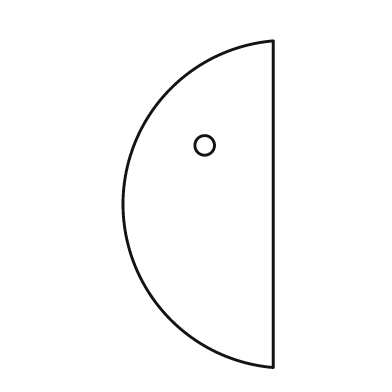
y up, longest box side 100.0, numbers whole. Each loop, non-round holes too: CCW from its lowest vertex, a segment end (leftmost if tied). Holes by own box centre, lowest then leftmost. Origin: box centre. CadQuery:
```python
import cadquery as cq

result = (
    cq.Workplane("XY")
    .moveTo(23.0, -50.0)
    .lineTo(23.0, 50.0)
    .threePointArc((-23.0, 0.0), (23.0, -50.0))
    .close()
    .moveTo(2.0, 18.0)
    .circle(3.0)
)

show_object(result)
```